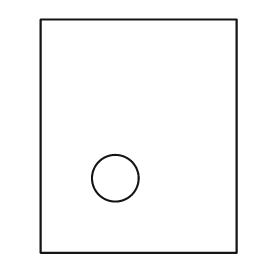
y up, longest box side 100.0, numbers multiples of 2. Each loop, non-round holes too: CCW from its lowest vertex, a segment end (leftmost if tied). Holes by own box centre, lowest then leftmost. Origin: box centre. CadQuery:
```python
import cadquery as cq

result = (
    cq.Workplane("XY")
    .moveTo(-42.0, -50.0)
    .lineTo(42.0, -50.0)
    .lineTo(42.0, 50.0)
    .lineTo(-42.0, 50.0)
    .close()
    .moveTo(-10.0, -18.0)
    .circle(10.0)
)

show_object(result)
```